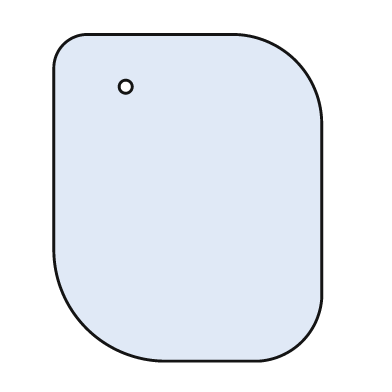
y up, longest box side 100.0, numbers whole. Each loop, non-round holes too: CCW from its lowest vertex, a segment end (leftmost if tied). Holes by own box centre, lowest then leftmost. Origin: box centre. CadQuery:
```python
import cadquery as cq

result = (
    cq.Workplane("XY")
    .moveTo(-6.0, -50.0)
    .lineTo(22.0, -50.0)
    .threePointArc((35.0, -44.0), (41.0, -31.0))
    .lineTo(41.0, 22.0)
    .threePointArc((33.0, 42.0), (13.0, 50.0))
    .lineTo(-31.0, 50.0)
    .threePointArc((-38.0, 47.0), (-41.0, 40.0))
    .lineTo(-41.0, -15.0)
    .threePointArc((-31.0, -40.0), (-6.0, -50.0))
    .close()
    .moveTo(-19.0, 34.0)
    .circle(2.0)
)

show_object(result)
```